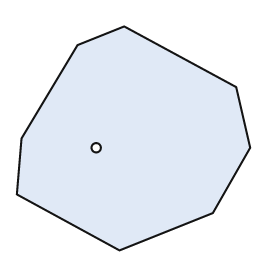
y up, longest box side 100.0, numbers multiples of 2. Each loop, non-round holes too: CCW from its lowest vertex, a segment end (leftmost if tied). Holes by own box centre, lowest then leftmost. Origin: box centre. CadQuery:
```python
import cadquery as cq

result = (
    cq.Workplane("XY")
    .moveTo(-6.0, -48.0)
    .lineTo(34.0, -32.0)
    .lineTo(50.0, -4.0)
    .lineTo(44.0, 22.0)
    .lineTo(-4.0, 48.0)
    .lineTo(-24.0, 40.0)
    .lineTo(-48.0, 0.0)
    .lineTo(-50.0, -24.0)
    .close()
    .moveTo(-16.0, -4.0)
    .circle(2.0)
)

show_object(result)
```